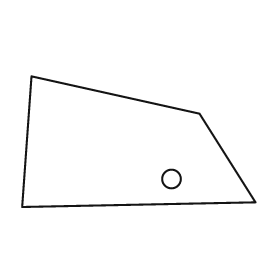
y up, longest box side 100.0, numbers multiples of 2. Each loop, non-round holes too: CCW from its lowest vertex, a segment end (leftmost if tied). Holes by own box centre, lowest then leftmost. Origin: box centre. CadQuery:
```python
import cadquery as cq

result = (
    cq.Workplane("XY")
    .moveTo(-50.0, -28.0)
    .lineTo(50.0, -26.0)
    .lineTo(26.0, 12.0)
    .lineTo(-46.0, 28.0)
    .close()
    .moveTo(14.0, -16.0)
    .circle(4.0)
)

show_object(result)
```